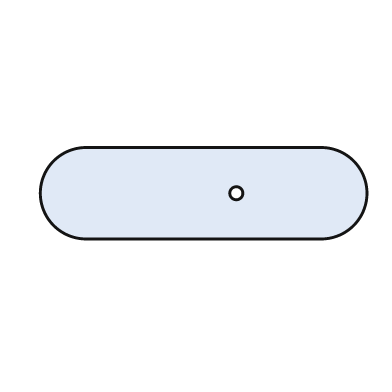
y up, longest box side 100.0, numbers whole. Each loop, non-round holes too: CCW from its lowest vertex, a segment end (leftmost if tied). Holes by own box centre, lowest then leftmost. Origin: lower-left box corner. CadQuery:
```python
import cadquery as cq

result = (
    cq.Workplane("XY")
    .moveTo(14.0, 0.0)
    .lineTo(86.0, 0.0)
    .threePointArc((100.0, 14.0), (86.0, 28.0))
    .lineTo(14.0, 28.0)
    .threePointArc((0.0, 14.0), (14.0, 0.0))
    .close()
    .moveTo(60.0, 14.0)
    .circle(2.0)
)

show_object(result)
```